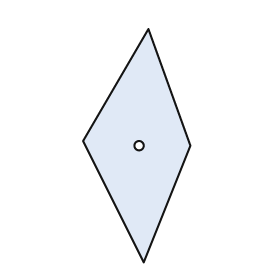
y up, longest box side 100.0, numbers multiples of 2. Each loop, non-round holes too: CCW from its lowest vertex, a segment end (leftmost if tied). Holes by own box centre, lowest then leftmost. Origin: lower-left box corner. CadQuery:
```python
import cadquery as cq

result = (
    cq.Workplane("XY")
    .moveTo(26.0, 0.0)
    .lineTo(46.0, 50.0)
    .lineTo(28.0, 100.0)
    .lineTo(0.0, 52.0)
    .close()
    .moveTo(24.0, 50.0)
    .circle(2.0)
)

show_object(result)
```